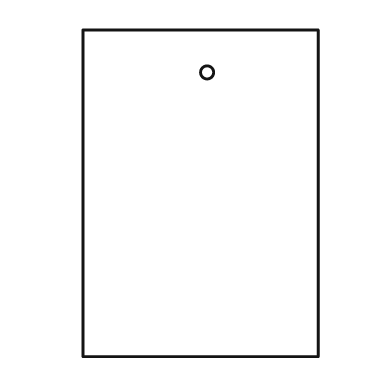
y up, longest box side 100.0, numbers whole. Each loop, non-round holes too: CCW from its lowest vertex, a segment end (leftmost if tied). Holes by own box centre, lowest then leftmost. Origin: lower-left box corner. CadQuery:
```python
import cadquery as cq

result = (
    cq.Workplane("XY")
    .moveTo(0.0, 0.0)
    .lineTo(72.0, 0.0)
    .lineTo(72.0, 100.0)
    .lineTo(0.0, 100.0)
    .close()
    .moveTo(38.0, 87.0)
    .circle(2.0)
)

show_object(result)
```